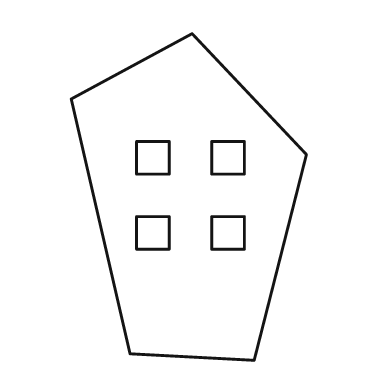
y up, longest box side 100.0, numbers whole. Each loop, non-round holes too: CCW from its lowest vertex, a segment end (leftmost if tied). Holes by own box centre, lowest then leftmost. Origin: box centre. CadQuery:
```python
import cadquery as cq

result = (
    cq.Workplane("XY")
    .moveTo(20.0, -50.0)
    .lineTo(36.0, 13.0)
    .lineTo(1.0, 50.0)
    .lineTo(-36.0, 30.0)
    .lineTo(-18.0, -48.0)
    .close()
    .moveTo(-16.0, -16.0)
    .lineTo(-6.0, -16.0)
    .lineTo(-6.0, -6.0)
    .lineTo(-16.0, -6.0)
    .close()
    .moveTo(7.0, -16.0)
    .lineTo(17.0, -16.0)
    .lineTo(17.0, -6.0)
    .lineTo(7.0, -6.0)
    .close()
    .moveTo(-16.0, 7.0)
    .lineTo(-6.0, 7.0)
    .lineTo(-6.0, 17.0)
    .lineTo(-16.0, 17.0)
    .close()
    .moveTo(7.0, 7.0)
    .lineTo(17.0, 7.0)
    .lineTo(17.0, 17.0)
    .lineTo(7.0, 17.0)
    .close()
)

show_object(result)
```